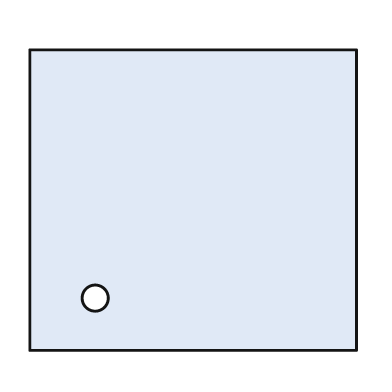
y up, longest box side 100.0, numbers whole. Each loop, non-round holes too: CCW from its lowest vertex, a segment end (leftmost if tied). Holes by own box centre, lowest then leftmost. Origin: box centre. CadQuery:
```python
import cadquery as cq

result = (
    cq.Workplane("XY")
    .moveTo(-50.0, -46.0)
    .lineTo(50.0, -46.0)
    .lineTo(50.0, 46.0)
    .lineTo(-50.0, 46.0)
    .close()
    .moveTo(-30.0, -30.0)
    .circle(4.0)
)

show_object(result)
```